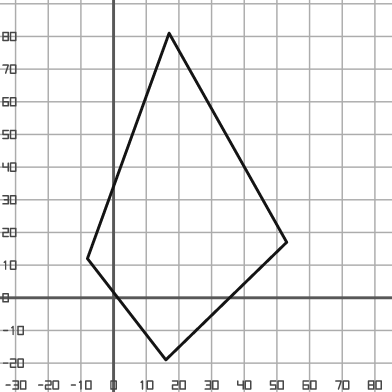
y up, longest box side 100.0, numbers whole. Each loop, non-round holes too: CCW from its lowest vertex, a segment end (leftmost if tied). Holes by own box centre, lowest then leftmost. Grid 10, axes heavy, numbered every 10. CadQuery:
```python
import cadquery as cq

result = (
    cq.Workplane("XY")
    .moveTo(16.0, -19.0)
    .lineTo(53.0, 17.0)
    .lineTo(17.0, 81.0)
    .lineTo(-8.0, 12.0)
    .close()
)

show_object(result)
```